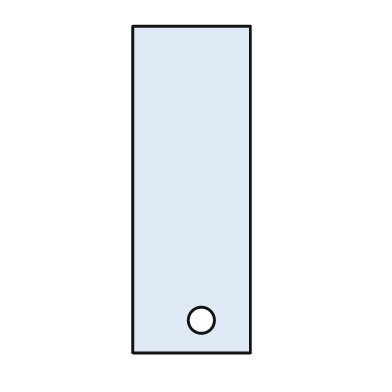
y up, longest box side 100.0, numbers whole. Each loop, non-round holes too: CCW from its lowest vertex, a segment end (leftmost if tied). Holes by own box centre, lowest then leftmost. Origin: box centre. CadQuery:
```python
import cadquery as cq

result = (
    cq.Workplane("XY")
    .moveTo(-18.0, -50.0)
    .lineTo(18.0, -50.0)
    .lineTo(18.0, 50.0)
    .lineTo(-18.0, 50.0)
    .close()
    .moveTo(3.0, -40.0)
    .circle(4.0)
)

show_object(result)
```